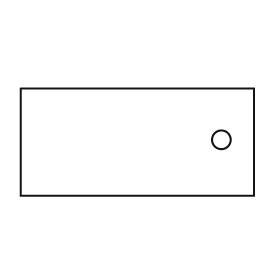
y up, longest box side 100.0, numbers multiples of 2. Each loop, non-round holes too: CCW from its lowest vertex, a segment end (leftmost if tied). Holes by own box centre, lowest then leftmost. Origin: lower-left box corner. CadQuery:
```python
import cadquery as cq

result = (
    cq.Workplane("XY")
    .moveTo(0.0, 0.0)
    .lineTo(100.0, 0.0)
    .lineTo(100.0, 46.0)
    .lineTo(0.0, 46.0)
    .close()
    .moveTo(86.0, 24.0)
    .circle(4.0)
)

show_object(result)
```